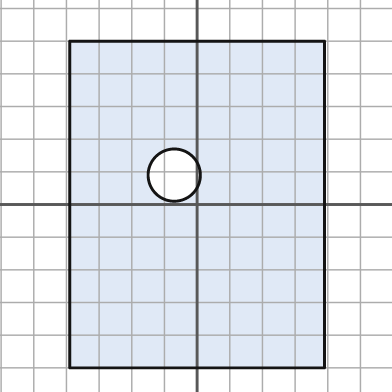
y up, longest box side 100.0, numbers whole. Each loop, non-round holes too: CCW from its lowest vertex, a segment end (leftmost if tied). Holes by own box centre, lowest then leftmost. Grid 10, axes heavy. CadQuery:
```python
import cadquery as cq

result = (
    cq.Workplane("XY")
    .moveTo(-39.0, -50.0)
    .lineTo(39.0, -50.0)
    .lineTo(39.0, 50.0)
    .lineTo(-39.0, 50.0)
    .close()
    .moveTo(-7.0, 9.0)
    .circle(8.0)
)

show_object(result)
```